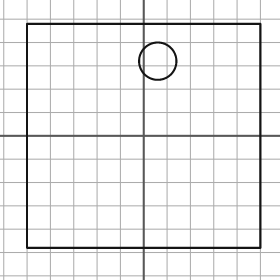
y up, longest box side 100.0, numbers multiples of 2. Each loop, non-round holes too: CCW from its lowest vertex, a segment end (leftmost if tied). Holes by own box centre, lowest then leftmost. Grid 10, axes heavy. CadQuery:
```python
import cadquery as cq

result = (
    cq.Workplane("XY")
    .moveTo(-50.0, -48.0)
    .lineTo(50.0, -48.0)
    .lineTo(50.0, 48.0)
    .lineTo(-50.0, 48.0)
    .close()
    .moveTo(6.0, 32.0)
    .circle(8.0)
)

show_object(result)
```